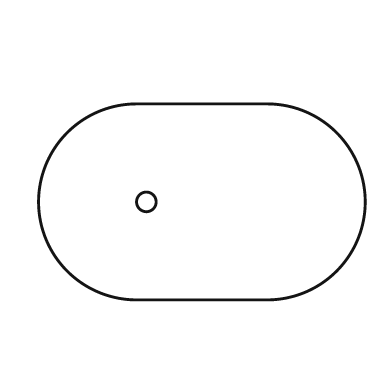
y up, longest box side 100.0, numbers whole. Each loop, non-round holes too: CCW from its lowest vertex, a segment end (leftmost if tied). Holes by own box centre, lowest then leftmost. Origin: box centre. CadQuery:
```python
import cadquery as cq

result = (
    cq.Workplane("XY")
    .moveTo(-20.0, -30.0)
    .lineTo(20.0, -30.0)
    .threePointArc((50.0, 0.0), (20.0, 30.0))
    .lineTo(-20.0, 30.0)
    .threePointArc((-50.0, 0.0), (-20.0, -30.0))
    .close()
    .moveTo(-17.0, 0.0)
    .circle(3.0)
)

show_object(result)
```